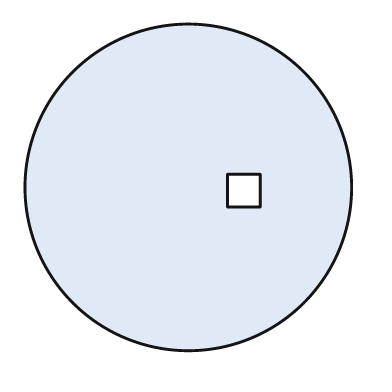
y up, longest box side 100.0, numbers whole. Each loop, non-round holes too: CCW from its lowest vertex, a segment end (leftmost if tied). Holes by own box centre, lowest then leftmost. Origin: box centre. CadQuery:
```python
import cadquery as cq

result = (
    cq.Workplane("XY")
    .moveTo(0.0, 0.0)
    .circle(50.0)
    .moveTo(12.0, -6.0)
    .lineTo(22.0, -6.0)
    .lineTo(22.0, 4.0)
    .lineTo(12.0, 4.0)
    .close()
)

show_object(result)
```